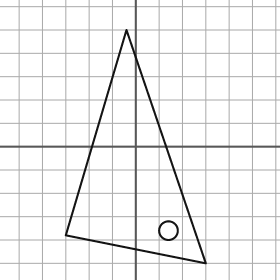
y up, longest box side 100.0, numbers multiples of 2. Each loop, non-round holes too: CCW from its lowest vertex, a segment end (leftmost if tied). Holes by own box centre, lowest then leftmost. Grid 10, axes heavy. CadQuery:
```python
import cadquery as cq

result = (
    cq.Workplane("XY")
    .moveTo(30.0, -50.0)
    .lineTo(-4.0, 50.0)
    .lineTo(-30.0, -38.0)
    .close()
    .moveTo(14.0, -36.0)
    .circle(4.0)
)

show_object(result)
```